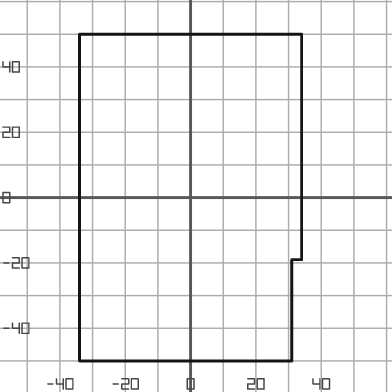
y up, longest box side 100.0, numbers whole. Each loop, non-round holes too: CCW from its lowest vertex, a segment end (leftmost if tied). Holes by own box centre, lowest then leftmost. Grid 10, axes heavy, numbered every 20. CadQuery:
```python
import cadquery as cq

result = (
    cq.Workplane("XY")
    .moveTo(-34.0, -50.0)
    .lineTo(31.0, -50.0)
    .lineTo(31.0, -19.0)
    .lineTo(34.0, -19.0)
    .lineTo(34.0, 50.0)
    .lineTo(-34.0, 50.0)
    .close()
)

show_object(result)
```